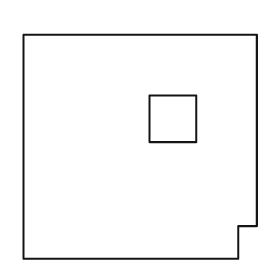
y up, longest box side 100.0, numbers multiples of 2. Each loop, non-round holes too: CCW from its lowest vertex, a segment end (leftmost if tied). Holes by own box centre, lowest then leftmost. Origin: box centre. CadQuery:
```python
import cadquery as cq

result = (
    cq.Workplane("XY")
    .moveTo(-50.0, -48.0)
    .lineTo(42.0, -48.0)
    .lineTo(42.0, -34.0)
    .lineTo(50.0, -34.0)
    .lineTo(50.0, 48.0)
    .lineTo(-50.0, 48.0)
    .close()
    .moveTo(4.0, 2.0)
    .lineTo(24.0, 2.0)
    .lineTo(24.0, 22.0)
    .lineTo(4.0, 22.0)
    .close()
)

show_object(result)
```